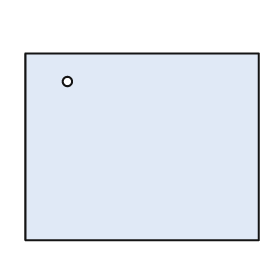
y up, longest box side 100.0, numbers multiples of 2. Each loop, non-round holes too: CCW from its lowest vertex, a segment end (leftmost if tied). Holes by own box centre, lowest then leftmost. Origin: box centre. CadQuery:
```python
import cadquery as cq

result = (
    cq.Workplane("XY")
    .moveTo(-50.0, -40.0)
    .lineTo(50.0, -40.0)
    .lineTo(50.0, 40.0)
    .lineTo(-50.0, 40.0)
    .close()
    .moveTo(-32.0, 28.0)
    .circle(2.0)
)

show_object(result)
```